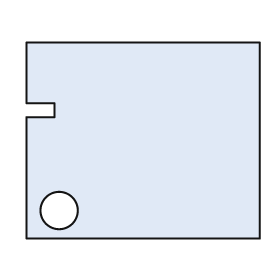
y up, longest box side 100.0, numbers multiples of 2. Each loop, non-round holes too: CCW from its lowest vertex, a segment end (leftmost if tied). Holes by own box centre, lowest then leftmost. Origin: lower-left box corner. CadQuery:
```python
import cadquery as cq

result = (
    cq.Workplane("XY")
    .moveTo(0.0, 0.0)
    .lineTo(100.0, 0.0)
    .lineTo(100.0, 84.0)
    .lineTo(0.0, 84.0)
    .lineTo(0.0, 58.0)
    .lineTo(12.0, 58.0)
    .lineTo(12.0, 52.0)
    .lineTo(0.0, 52.0)
    .close()
    .moveTo(14.0, 12.0)
    .circle(8.0)
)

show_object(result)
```